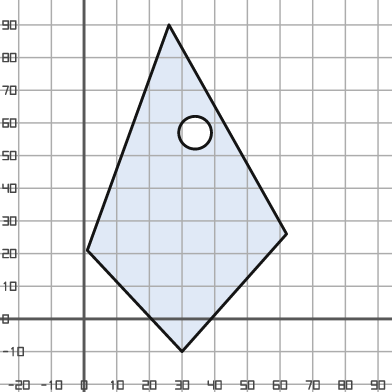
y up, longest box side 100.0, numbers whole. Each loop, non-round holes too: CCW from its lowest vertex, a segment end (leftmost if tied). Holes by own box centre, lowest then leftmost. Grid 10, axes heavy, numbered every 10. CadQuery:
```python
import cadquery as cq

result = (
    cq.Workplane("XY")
    .moveTo(30.0, -10.0)
    .lineTo(62.0, 26.0)
    .lineTo(26.0, 90.0)
    .lineTo(1.0, 21.0)
    .close()
    .moveTo(34.0, 57.0)
    .circle(5.0)
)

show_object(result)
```